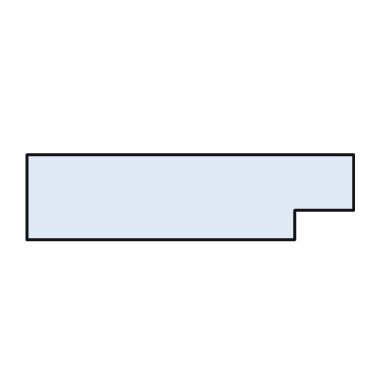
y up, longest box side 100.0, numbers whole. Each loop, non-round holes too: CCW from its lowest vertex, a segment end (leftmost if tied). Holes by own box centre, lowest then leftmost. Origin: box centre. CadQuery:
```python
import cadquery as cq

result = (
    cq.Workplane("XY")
    .moveTo(-50.0, -13.0)
    .lineTo(32.0, -13.0)
    .lineTo(32.0, -4.0)
    .lineTo(50.0, -4.0)
    .lineTo(50.0, 13.0)
    .lineTo(-50.0, 13.0)
    .close()
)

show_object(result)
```